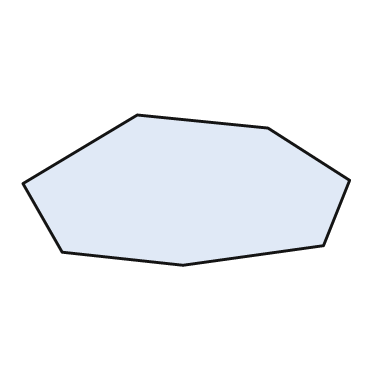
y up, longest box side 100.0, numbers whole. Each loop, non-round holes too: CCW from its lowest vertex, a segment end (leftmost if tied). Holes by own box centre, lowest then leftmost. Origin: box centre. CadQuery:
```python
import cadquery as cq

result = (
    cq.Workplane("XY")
    .moveTo(-1.0, -23.0)
    .lineTo(42.0, -17.0)
    .lineTo(50.0, 3.0)
    .lineTo(25.0, 19.0)
    .lineTo(-15.0, 23.0)
    .lineTo(-50.0, 2.0)
    .lineTo(-38.0, -19.0)
    .close()
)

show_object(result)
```